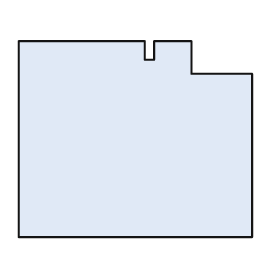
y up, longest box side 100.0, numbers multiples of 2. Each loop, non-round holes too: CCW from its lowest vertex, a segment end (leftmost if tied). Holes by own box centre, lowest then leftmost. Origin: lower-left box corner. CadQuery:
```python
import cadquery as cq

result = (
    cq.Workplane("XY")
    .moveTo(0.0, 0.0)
    .lineTo(100.0, 0.0)
    .lineTo(100.0, 70.0)
    .lineTo(74.0, 70.0)
    .lineTo(74.0, 84.0)
    .lineTo(58.0, 84.0)
    .lineTo(58.0, 76.0)
    .lineTo(54.0, 76.0)
    .lineTo(54.0, 84.0)
    .lineTo(0.0, 84.0)
    .close()
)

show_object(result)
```